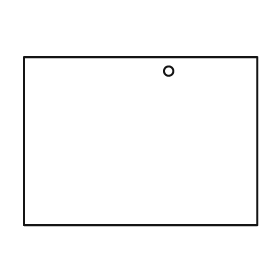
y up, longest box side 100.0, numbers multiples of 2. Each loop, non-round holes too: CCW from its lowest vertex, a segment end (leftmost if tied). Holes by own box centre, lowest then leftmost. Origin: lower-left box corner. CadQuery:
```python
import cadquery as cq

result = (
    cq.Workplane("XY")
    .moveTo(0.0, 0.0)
    .lineTo(100.0, 0.0)
    .lineTo(100.0, 72.0)
    .lineTo(0.0, 72.0)
    .close()
    .moveTo(62.0, 66.0)
    .circle(2.0)
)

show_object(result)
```